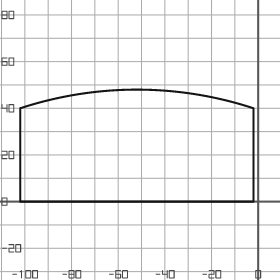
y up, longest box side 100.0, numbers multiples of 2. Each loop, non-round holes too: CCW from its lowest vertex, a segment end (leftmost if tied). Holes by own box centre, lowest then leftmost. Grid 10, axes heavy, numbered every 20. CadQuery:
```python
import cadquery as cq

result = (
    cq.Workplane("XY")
    .moveTo(-102.0, 0.0)
    .lineTo(-2.0, 0.0)
    .lineTo(-2.0, 40.0)
    .threePointArc((-52.0, 48.0), (-102.0, 40.0))
    .close()
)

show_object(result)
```